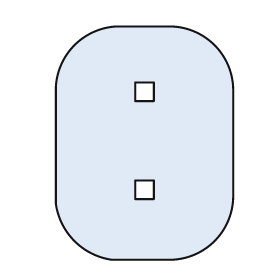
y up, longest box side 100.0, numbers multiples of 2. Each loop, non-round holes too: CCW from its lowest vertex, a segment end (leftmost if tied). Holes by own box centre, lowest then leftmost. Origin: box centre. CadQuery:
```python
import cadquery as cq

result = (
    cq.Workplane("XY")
    .moveTo(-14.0, -50.0)
    .lineTo(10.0, -50.0)
    .threePointArc((30.0, -42.0), (38.0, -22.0))
    .lineTo(38.0, 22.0)
    .threePointArc((30.0, 42.0), (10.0, 50.0))
    .lineTo(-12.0, 50.0)
    .threePointArc((-30.0, 42.0), (-38.0, 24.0))
    .lineTo(-38.0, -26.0)
    .threePointArc((-30.0, -42.0), (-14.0, -50.0))
    .close()
    .moveTo(-4.0, -24.0)
    .lineTo(4.0, -24.0)
    .lineTo(4.0, -16.0)
    .lineTo(-4.0, -16.0)
    .close()
    .moveTo(-4.0, 18.0)
    .lineTo(4.0, 18.0)
    .lineTo(4.0, 26.0)
    .lineTo(-4.0, 26.0)
    .close()
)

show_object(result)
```